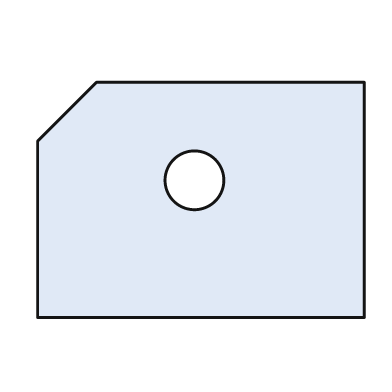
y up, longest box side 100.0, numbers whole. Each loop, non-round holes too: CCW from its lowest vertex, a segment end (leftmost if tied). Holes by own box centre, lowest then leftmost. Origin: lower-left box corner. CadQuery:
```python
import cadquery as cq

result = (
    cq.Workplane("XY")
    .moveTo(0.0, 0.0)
    .lineTo(100.0, 0.0)
    .lineTo(100.0, 72.0)
    .lineTo(18.0, 72.0)
    .lineTo(0.0, 54.0)
    .close()
    .moveTo(48.0, 42.0)
    .circle(9.0)
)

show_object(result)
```